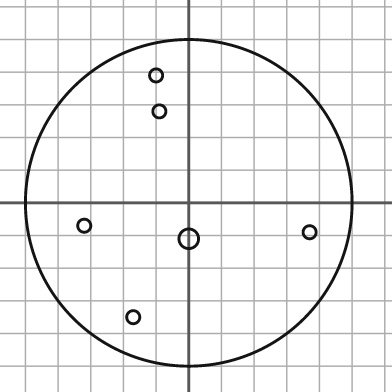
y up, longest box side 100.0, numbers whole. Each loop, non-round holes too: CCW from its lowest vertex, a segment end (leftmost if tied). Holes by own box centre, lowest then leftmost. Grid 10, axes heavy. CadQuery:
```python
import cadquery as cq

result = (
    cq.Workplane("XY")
    .moveTo(0.0, 0.0)
    .circle(50.0)
    .moveTo(-17.0, -35.0)
    .circle(2.0)
    .moveTo(0.0, -11.0)
    .circle(3.0)
    .moveTo(37.0, -9.0)
    .circle(2.0)
    .moveTo(-32.0, -7.0)
    .circle(2.0)
    .moveTo(-9.0, 28.0)
    .circle(2.0)
    .moveTo(-10.0, 39.0)
    .circle(2.0)
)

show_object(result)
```